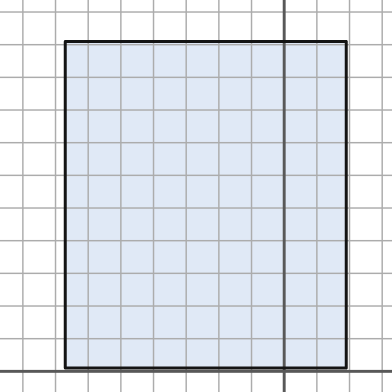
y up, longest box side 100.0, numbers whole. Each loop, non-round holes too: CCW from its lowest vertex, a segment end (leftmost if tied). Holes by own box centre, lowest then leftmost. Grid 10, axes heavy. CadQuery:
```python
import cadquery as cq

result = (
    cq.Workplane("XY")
    .moveTo(-67.0, 1.0)
    .lineTo(19.0, 1.0)
    .lineTo(19.0, 101.0)
    .lineTo(-67.0, 101.0)
    .close()
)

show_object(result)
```